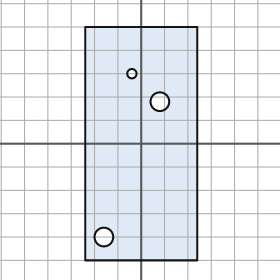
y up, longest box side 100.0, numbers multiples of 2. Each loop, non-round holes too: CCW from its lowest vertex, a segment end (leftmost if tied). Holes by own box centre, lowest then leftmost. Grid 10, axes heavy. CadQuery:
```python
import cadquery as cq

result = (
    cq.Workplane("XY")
    .moveTo(-24.0, -50.0)
    .lineTo(24.0, -50.0)
    .lineTo(24.0, 50.0)
    .lineTo(-24.0, 50.0)
    .close()
    .moveTo(-16.0, -40.0)
    .circle(4.0)
    .moveTo(8.0, 18.0)
    .circle(4.0)
    .moveTo(-4.0, 30.0)
    .circle(2.0)
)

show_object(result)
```